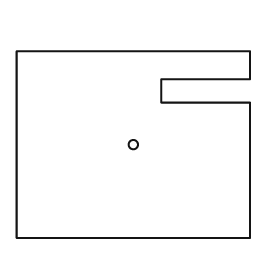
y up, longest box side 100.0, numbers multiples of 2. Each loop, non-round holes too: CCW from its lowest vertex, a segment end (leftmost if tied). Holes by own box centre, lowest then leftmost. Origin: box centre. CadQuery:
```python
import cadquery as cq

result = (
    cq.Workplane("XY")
    .moveTo(-50.0, -40.0)
    .lineTo(50.0, -40.0)
    .lineTo(50.0, 18.0)
    .lineTo(12.0, 18.0)
    .lineTo(12.0, 28.0)
    .lineTo(50.0, 28.0)
    .lineTo(50.0, 40.0)
    .lineTo(-50.0, 40.0)
    .close()
    .moveTo(0.0, 0.0)
    .circle(2.0)
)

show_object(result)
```